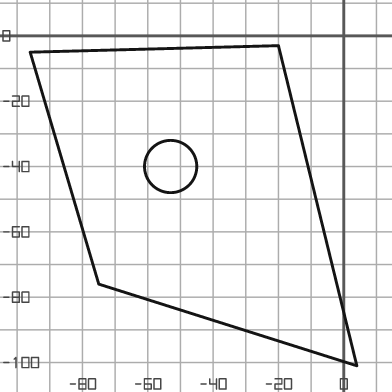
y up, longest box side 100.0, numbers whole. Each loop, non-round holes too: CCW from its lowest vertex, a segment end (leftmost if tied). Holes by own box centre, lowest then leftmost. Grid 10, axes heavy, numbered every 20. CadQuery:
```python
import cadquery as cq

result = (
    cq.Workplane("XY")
    .moveTo(4.0, -101.0)
    .lineTo(-20.0, -3.0)
    .lineTo(-96.0, -5.0)
    .lineTo(-75.0, -76.0)
    .close()
    .moveTo(-53.0, -40.0)
    .circle(8.0)
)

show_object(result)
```